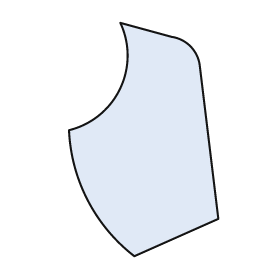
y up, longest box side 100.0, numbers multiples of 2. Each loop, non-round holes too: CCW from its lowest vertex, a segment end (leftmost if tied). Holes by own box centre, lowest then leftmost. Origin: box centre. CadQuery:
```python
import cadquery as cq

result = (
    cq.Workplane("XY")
    .moveTo(-4.0, -50.0)
    .lineTo(32.0, -34.0)
    .lineTo(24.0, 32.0)
    .threePointArc((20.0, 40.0), (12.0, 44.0))
    .lineTo(-10.0, 50.0)
    .threePointArc((-10.0, 22.0), (-32.0, 4.0))
    .threePointArc((-24.0, -26.0), (-4.0, -50.0))
    .close()
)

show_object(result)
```